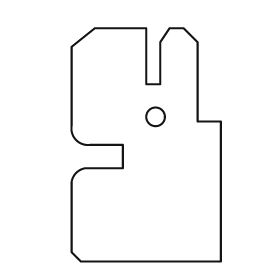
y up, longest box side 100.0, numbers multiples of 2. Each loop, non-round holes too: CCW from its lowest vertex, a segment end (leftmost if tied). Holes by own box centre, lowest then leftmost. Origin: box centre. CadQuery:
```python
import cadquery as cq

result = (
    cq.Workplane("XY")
    .moveTo(-28.0, -50.0)
    .lineTo(32.0, -50.0)
    .lineTo(32.0, 10.0)
    .lineTo(22.0, 10.0)
    .lineTo(22.0, 44.0)
    .lineTo(16.0, 50.0)
    .lineTo(10.0, 50.0)
    .lineTo(6.0, 44.0)
    .lineTo(6.0, 26.0)
    .lineTo(0.0, 26.0)
    .lineTo(0.0, 50.0)
    .lineTo(-22.0, 50.0)
    .lineTo(-32.0, 42.0)
    .lineTo(-32.0, 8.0)
    .threePointArc((-30.0, 2.0), (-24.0, 0.0))
    .lineTo(-10.0, 0.0)
    .lineTo(-10.0, -10.0)
    .lineTo(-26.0, -10.0)
    .threePointArc((-30.0, -12.0), (-32.0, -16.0))
    .lineTo(-32.0, -46.0)
    .close()
    .moveTo(4.0, 12.0)
    .circle(4.0)
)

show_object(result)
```